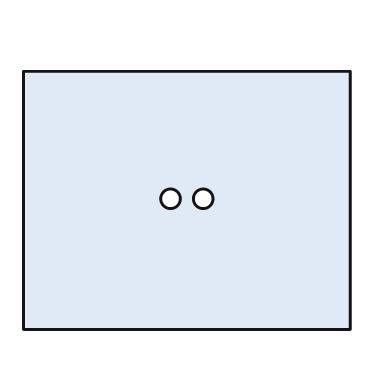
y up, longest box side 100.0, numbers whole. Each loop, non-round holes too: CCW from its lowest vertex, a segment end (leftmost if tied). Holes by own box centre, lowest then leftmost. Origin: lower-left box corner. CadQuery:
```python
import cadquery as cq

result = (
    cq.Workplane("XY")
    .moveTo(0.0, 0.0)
    .lineTo(100.0, 0.0)
    .lineTo(100.0, 79.0)
    .lineTo(0.0, 79.0)
    .close()
    .moveTo(45.0, 40.0)
    .circle(3.0)
    .moveTo(55.0, 40.0)
    .circle(3.0)
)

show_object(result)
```